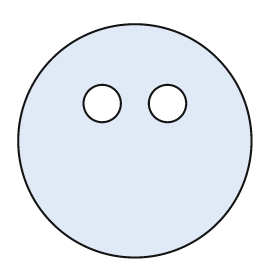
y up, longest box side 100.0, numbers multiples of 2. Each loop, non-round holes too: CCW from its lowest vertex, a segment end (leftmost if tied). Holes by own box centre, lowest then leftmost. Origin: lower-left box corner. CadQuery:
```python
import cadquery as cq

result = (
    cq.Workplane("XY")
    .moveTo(50.0, 50.0)
    .circle(50.0)
    .moveTo(36.0, 66.0)
    .circle(8.0)
    .moveTo(64.0, 66.0)
    .circle(8.0)
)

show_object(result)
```